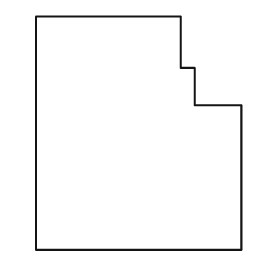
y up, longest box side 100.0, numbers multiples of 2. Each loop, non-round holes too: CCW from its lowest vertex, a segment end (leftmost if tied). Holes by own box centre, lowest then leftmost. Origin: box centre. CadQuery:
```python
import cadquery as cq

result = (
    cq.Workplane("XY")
    .moveTo(-44.0, -50.0)
    .lineTo(44.0, -50.0)
    .lineTo(44.0, 12.0)
    .lineTo(24.0, 12.0)
    .lineTo(24.0, 28.0)
    .lineTo(18.0, 28.0)
    .lineTo(18.0, 50.0)
    .lineTo(-44.0, 50.0)
    .close()
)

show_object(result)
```